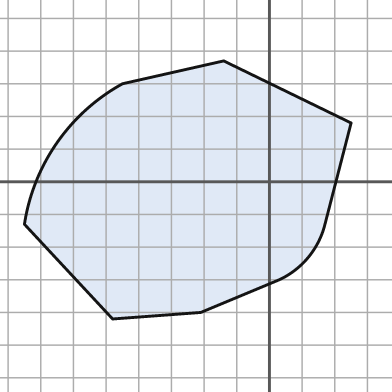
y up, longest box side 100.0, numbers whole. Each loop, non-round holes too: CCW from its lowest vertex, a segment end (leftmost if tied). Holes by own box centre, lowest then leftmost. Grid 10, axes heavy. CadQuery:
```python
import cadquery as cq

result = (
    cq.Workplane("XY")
    .moveTo(-48.0, -42.0)
    .lineTo(-21.0, -40.0)
    .lineTo(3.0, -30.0)
    .threePointArc((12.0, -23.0), (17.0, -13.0))
    .lineTo(25.0, 18.0)
    .lineTo(-14.0, 37.0)
    .lineTo(-45.0, 30.0)
    .threePointArc((-65.0, 12.0), (-75.0, -13.0))
    .close()
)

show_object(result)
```